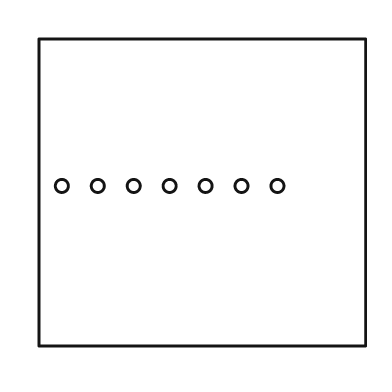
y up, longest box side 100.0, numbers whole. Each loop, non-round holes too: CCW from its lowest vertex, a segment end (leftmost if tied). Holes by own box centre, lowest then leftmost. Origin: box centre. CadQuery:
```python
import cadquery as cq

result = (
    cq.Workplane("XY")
    .moveTo(-50.0, -47.0)
    .lineTo(50.0, -47.0)
    .lineTo(50.0, 47.0)
    .lineTo(-50.0, 47.0)
    .close()
    .moveTo(-43.0, 2.0)
    .circle(2.0)
    .moveTo(-32.0, 2.0)
    .circle(2.0)
    .moveTo(-21.0, 2.0)
    .circle(2.0)
    .moveTo(-10.0, 2.0)
    .circle(2.0)
    .moveTo(1.0, 2.0)
    .circle(2.0)
    .moveTo(12.0, 2.0)
    .circle(2.0)
    .moveTo(23.0, 2.0)
    .circle(2.0)
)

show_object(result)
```